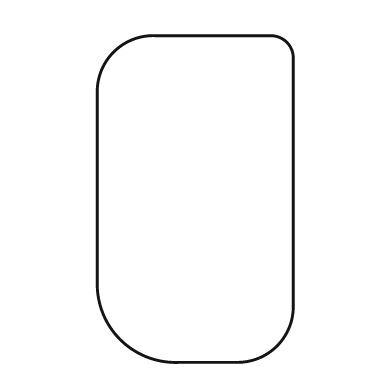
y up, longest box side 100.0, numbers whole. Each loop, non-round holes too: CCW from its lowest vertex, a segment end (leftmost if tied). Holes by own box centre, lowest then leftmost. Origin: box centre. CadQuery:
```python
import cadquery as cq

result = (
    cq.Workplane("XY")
    .moveTo(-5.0, -50.0)
    .lineTo(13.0, -50.0)
    .threePointArc((25.0, -45.0), (30.0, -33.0))
    .lineTo(30.0, 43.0)
    .threePointArc((28.0, 48.0), (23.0, 50.0))
    .lineTo(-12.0, 50.0)
    .threePointArc((-25.0, 45.0), (-30.0, 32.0))
    .lineTo(-30.0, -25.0)
    .threePointArc((-23.0, -43.0), (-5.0, -50.0))
    .close()
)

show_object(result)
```